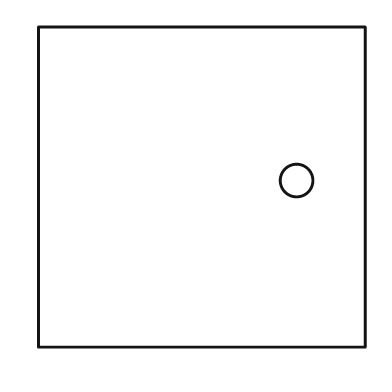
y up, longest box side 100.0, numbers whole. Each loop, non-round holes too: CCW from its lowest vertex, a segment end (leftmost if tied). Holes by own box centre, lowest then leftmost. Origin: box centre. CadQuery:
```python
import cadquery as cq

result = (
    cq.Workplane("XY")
    .moveTo(-50.0, -49.0)
    .lineTo(50.0, -49.0)
    .lineTo(50.0, 49.0)
    .lineTo(-50.0, 49.0)
    .close()
    .moveTo(29.0, 2.0)
    .circle(5.0)
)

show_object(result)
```